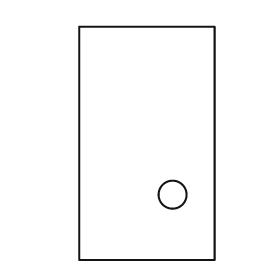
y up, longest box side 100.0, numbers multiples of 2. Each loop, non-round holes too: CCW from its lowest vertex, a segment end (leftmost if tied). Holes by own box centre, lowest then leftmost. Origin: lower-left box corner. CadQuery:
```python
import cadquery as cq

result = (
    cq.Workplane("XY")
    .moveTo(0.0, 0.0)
    .lineTo(58.0, 0.0)
    .lineTo(58.0, 100.0)
    .lineTo(0.0, 100.0)
    .close()
    .moveTo(40.0, 28.0)
    .circle(6.0)
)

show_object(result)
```